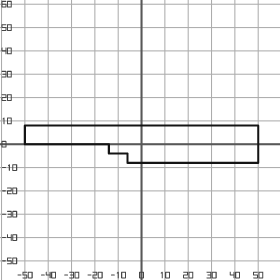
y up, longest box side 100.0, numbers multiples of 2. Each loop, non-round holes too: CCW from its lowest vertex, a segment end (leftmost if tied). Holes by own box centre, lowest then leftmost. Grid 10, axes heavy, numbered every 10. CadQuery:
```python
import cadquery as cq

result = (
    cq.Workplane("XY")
    .moveTo(-6.0, -8.0)
    .lineTo(50.0, -8.0)
    .lineTo(50.0, 8.0)
    .lineTo(-50.0, 8.0)
    .lineTo(-50.0, 0.0)
    .lineTo(-14.0, 0.0)
    .lineTo(-14.0, -4.0)
    .lineTo(-6.0, -4.0)
    .close()
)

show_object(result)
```